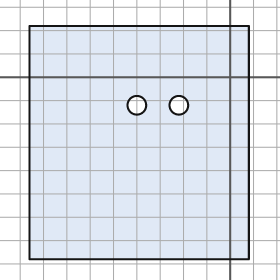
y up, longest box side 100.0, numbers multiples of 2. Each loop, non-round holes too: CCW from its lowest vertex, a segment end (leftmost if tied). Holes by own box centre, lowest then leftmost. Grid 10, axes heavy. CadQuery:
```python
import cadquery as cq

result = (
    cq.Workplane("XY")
    .moveTo(-86.0, -78.0)
    .lineTo(8.0, -78.0)
    .lineTo(8.0, 22.0)
    .lineTo(-86.0, 22.0)
    .close()
    .moveTo(-40.0, -12.0)
    .circle(4.0)
    .moveTo(-22.0, -12.0)
    .circle(4.0)
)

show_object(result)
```